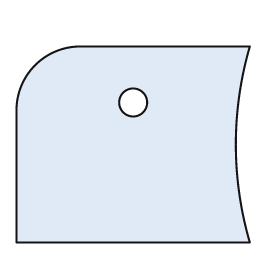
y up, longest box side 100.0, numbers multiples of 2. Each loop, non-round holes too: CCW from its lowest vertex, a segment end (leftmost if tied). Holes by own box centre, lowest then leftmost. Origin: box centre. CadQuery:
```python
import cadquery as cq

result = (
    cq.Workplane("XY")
    .moveTo(-50.0, -42.0)
    .lineTo(50.0, -42.0)
    .threePointArc((44.0, 0.0), (50.0, 42.0))
    .lineTo(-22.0, 42.0)
    .threePointArc((-42.0, 34.0), (-50.0, 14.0))
    .close()
    .moveTo(0.0, 18.0)
    .circle(6.0)
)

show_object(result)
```